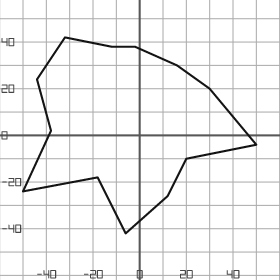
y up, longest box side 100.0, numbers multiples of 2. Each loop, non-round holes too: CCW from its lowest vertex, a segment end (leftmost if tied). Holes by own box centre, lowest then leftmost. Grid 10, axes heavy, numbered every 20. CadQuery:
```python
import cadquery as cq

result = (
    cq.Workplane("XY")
    .moveTo(-6.0, -42.0)
    .lineTo(12.0, -26.0)
    .lineTo(20.0, -10.0)
    .lineTo(50.0, -4.0)
    .lineTo(30.0, 20.0)
    .lineTo(16.0, 30.0)
    .lineTo(-2.0, 38.0)
    .lineTo(-12.0, 38.0)
    .lineTo(-32.0, 42.0)
    .lineTo(-44.0, 24.0)
    .lineTo(-38.0, 2.0)
    .lineTo(-50.0, -24.0)
    .lineTo(-18.0, -18.0)
    .close()
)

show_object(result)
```